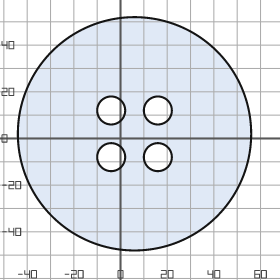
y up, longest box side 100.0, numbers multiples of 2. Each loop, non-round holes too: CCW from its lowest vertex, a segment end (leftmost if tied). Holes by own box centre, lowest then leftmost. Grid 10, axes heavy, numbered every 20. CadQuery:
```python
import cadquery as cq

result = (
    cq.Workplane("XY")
    .moveTo(6.0, 2.0)
    .circle(50.0)
    .moveTo(-4.0, -8.0)
    .circle(6.0)
    .moveTo(16.0, -8.0)
    .circle(6.0)
    .moveTo(-4.0, 12.0)
    .circle(6.0)
    .moveTo(16.0, 12.0)
    .circle(6.0)
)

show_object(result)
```